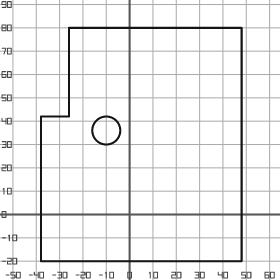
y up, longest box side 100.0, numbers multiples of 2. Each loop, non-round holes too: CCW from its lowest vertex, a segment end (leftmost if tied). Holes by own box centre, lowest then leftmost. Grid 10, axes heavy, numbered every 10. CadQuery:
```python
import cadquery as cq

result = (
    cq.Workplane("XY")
    .moveTo(-38.0, -20.0)
    .lineTo(48.0, -20.0)
    .lineTo(48.0, 80.0)
    .lineTo(-26.0, 80.0)
    .lineTo(-26.0, 42.0)
    .lineTo(-38.0, 42.0)
    .close()
    .moveTo(-10.0, 36.0)
    .circle(6.0)
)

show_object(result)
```